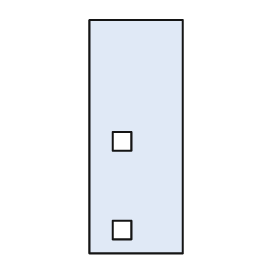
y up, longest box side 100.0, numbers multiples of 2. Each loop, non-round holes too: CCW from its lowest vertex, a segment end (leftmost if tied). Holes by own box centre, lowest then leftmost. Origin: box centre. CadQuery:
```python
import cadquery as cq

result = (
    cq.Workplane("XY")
    .moveTo(-20.0, -50.0)
    .lineTo(20.0, -50.0)
    .lineTo(20.0, 50.0)
    .lineTo(-20.0, 50.0)
    .close()
    .moveTo(-10.0, -44.0)
    .lineTo(-2.0, -44.0)
    .lineTo(-2.0, -36.0)
    .lineTo(-10.0, -36.0)
    .close()
    .moveTo(-10.0, -6.0)
    .lineTo(-2.0, -6.0)
    .lineTo(-2.0, 2.0)
    .lineTo(-10.0, 2.0)
    .close()
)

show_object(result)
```